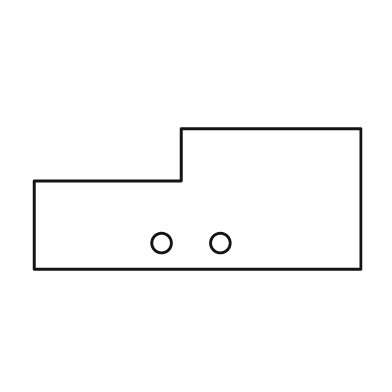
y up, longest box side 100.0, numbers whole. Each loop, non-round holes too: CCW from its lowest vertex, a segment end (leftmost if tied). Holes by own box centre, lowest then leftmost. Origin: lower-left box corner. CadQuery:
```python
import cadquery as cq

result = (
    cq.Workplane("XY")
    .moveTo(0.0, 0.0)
    .lineTo(100.0, 0.0)
    .lineTo(100.0, 43.0)
    .lineTo(45.0, 43.0)
    .lineTo(45.0, 27.0)
    .lineTo(0.0, 27.0)
    .close()
    .moveTo(39.0, 8.0)
    .circle(3.0)
    .moveTo(57.0, 8.0)
    .circle(3.0)
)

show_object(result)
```